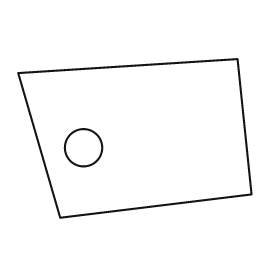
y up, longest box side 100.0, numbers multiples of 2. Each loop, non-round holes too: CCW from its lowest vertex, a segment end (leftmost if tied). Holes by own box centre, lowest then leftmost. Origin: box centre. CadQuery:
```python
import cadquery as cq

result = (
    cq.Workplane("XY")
    .moveTo(-32.0, -34.0)
    .lineTo(50.0, -24.0)
    .lineTo(44.0, 34.0)
    .lineTo(-50.0, 28.0)
    .close()
    .moveTo(-22.0, -4.0)
    .circle(8.0)
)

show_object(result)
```